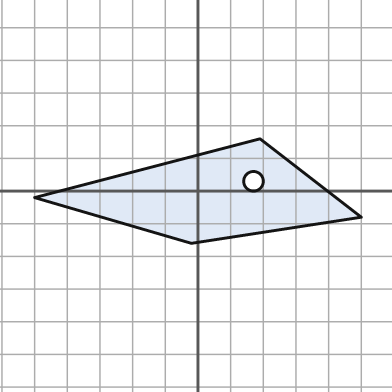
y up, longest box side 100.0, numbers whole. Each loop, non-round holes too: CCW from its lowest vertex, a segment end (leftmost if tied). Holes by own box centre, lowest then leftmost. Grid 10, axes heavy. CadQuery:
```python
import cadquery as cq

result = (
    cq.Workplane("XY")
    .moveTo(-2.0, -16.0)
    .lineTo(50.0, -8.0)
    .lineTo(19.0, 16.0)
    .lineTo(-50.0, -2.0)
    .close()
    .moveTo(17.0, 3.0)
    .circle(3.0)
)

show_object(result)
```